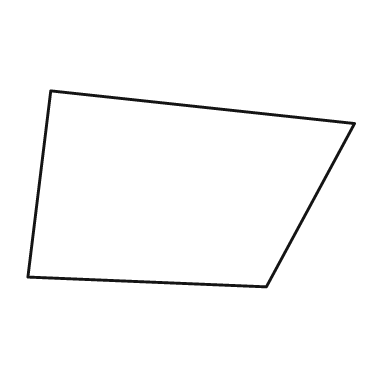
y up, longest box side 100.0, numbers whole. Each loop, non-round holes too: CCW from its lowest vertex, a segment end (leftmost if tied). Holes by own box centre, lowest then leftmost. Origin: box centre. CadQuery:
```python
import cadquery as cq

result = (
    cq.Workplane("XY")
    .moveTo(23.0, -30.0)
    .lineTo(50.0, 20.0)
    .lineTo(-43.0, 30.0)
    .lineTo(-50.0, -27.0)
    .close()
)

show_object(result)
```